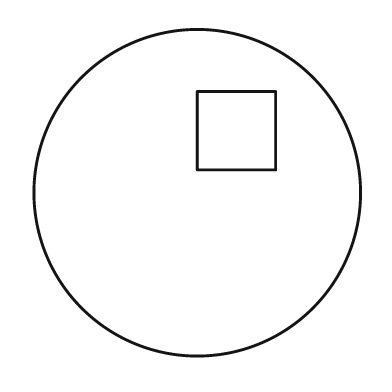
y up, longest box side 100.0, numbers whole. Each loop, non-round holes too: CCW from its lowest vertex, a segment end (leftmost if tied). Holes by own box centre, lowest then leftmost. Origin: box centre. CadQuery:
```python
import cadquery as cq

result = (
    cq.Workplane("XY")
    .moveTo(0.0, 0.0)
    .circle(50.0)
    .moveTo(0.0, 7.0)
    .lineTo(24.0, 7.0)
    .lineTo(24.0, 31.0)
    .lineTo(0.0, 31.0)
    .close()
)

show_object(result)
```